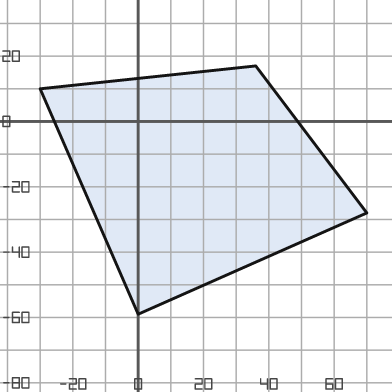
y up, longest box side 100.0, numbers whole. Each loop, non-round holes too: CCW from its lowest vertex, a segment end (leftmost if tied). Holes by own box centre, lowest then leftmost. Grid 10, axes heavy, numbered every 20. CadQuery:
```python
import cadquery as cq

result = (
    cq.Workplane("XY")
    .moveTo(0.0, -59.0)
    .lineTo(70.0, -28.0)
    .lineTo(36.0, 17.0)
    .lineTo(-30.0, 10.0)
    .close()
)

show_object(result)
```